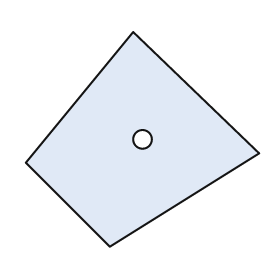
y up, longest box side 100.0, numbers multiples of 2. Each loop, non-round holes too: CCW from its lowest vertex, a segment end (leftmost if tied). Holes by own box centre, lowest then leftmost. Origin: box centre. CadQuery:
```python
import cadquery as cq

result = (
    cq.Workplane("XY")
    .moveTo(-14.0, -46.0)
    .lineTo(50.0, -6.0)
    .lineTo(-4.0, 46.0)
    .lineTo(-50.0, -10.0)
    .close()
    .moveTo(0.0, 0.0)
    .circle(4.0)
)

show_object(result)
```